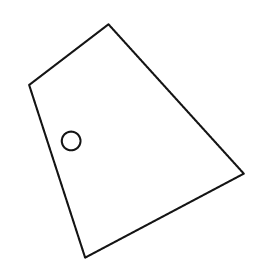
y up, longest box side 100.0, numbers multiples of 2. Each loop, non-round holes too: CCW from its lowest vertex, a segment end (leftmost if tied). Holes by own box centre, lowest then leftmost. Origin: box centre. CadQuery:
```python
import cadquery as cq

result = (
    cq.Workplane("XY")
    .moveTo(-22.0, -50.0)
    .lineTo(46.0, -14.0)
    .lineTo(-12.0, 50.0)
    .lineTo(-46.0, 24.0)
    .close()
    .moveTo(-28.0, 0.0)
    .circle(4.0)
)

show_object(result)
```